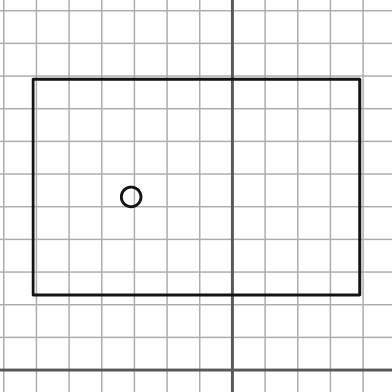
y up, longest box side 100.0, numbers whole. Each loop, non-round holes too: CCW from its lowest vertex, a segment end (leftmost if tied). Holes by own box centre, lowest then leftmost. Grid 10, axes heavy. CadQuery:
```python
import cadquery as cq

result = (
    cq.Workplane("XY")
    .moveTo(-61.0, 23.0)
    .lineTo(39.0, 23.0)
    .lineTo(39.0, 89.0)
    .lineTo(-61.0, 89.0)
    .close()
    .moveTo(-31.0, 53.0)
    .circle(3.0)
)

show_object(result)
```